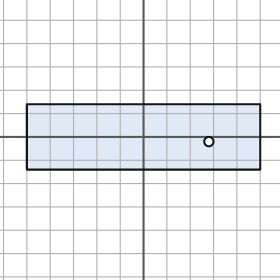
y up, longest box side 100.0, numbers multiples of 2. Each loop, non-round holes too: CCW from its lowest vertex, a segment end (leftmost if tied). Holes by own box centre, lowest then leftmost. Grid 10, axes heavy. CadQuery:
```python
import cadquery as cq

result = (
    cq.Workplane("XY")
    .moveTo(-50.0, -14.0)
    .lineTo(50.0, -14.0)
    .lineTo(50.0, 14.0)
    .lineTo(-50.0, 14.0)
    .close()
    .moveTo(28.0, -2.0)
    .circle(2.0)
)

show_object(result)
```